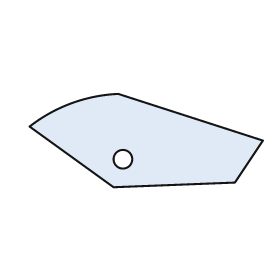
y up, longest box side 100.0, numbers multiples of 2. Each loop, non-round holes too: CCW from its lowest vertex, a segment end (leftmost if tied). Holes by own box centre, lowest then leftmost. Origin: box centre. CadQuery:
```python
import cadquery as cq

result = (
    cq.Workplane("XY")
    .moveTo(-14.0, -20.0)
    .lineTo(38.0, -18.0)
    .lineTo(50.0, 0.0)
    .lineTo(-12.0, 20.0)
    .threePointArc((-32.0, 16.0), (-50.0, 6.0))
    .close()
    .moveTo(-10.0, -8.0)
    .circle(4.0)
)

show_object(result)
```